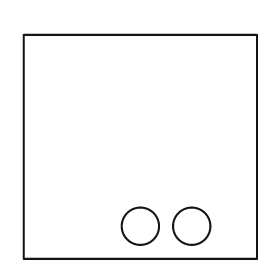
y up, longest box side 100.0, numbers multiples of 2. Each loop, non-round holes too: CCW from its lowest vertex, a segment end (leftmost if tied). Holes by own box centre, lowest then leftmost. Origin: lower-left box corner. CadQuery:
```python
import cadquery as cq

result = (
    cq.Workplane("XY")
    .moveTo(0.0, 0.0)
    .lineTo(100.0, 0.0)
    .lineTo(100.0, 96.0)
    .lineTo(0.0, 96.0)
    .close()
    .moveTo(50.0, 14.0)
    .circle(8.0)
    .moveTo(72.0, 14.0)
    .circle(8.0)
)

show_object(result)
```